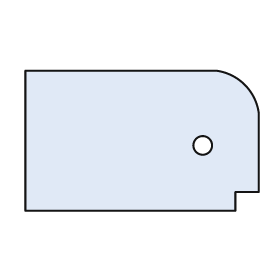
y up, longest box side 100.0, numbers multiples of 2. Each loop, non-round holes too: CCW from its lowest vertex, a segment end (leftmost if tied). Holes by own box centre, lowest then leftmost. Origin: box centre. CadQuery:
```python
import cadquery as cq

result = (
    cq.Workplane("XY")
    .moveTo(-50.0, -30.0)
    .lineTo(40.0, -30.0)
    .lineTo(40.0, -22.0)
    .lineTo(50.0, -22.0)
    .lineTo(50.0, 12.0)
    .threePointArc((44.0, 24.0), (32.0, 30.0))
    .lineTo(-50.0, 30.0)
    .close()
    .moveTo(26.0, -2.0)
    .circle(4.0)
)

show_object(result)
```